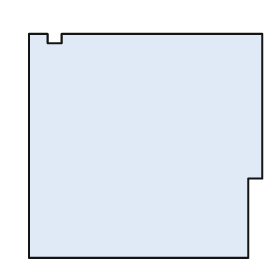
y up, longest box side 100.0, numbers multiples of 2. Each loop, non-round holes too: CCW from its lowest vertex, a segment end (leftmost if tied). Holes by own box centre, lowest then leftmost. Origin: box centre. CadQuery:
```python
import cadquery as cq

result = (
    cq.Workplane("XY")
    .moveTo(-50.0, -48.0)
    .lineTo(44.0, -48.0)
    .lineTo(44.0, -14.0)
    .lineTo(50.0, -14.0)
    .lineTo(50.0, 48.0)
    .lineTo(-36.0, 48.0)
    .lineTo(-36.0, 44.0)
    .lineTo(-42.0, 44.0)
    .lineTo(-42.0, 48.0)
    .lineTo(-50.0, 48.0)
    .close()
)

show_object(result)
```